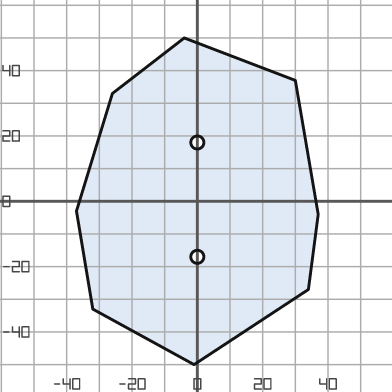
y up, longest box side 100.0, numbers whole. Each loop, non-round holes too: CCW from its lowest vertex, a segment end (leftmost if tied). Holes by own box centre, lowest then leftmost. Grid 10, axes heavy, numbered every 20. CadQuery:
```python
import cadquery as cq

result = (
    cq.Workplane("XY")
    .moveTo(-1.0, -50.0)
    .lineTo(34.0, -27.0)
    .lineTo(37.0, -4.0)
    .lineTo(30.0, 37.0)
    .lineTo(-4.0, 50.0)
    .lineTo(-26.0, 33.0)
    .lineTo(-37.0, -3.0)
    .lineTo(-32.0, -33.0)
    .close()
    .moveTo(0.0, -17.0)
    .circle(2.0)
    .moveTo(0.0, 18.0)
    .circle(2.0)
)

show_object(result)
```